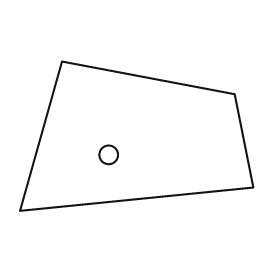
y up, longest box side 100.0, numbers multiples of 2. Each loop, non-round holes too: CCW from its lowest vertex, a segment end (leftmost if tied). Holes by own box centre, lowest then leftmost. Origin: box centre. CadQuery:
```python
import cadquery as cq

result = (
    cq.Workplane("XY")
    .moveTo(-50.0, -32.0)
    .lineTo(50.0, -22.0)
    .lineTo(42.0, 18.0)
    .lineTo(-32.0, 32.0)
    .close()
    .moveTo(-12.0, -8.0)
    .circle(4.0)
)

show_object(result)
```